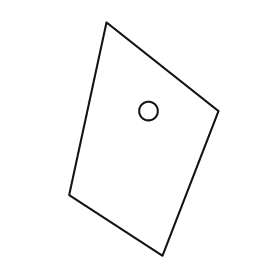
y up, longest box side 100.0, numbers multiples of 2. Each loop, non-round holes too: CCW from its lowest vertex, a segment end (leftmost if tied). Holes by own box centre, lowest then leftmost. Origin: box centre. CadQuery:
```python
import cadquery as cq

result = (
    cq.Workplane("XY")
    .moveTo(8.0, -50.0)
    .lineTo(32.0, 12.0)
    .lineTo(-16.0, 50.0)
    .lineTo(-32.0, -24.0)
    .close()
    .moveTo(2.0, 12.0)
    .circle(4.0)
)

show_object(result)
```